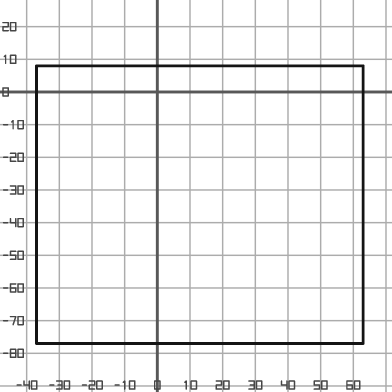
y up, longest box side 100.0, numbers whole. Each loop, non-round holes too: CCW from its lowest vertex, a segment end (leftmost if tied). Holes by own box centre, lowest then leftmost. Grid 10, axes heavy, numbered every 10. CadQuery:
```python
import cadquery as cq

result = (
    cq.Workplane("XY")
    .moveTo(-37.0, -77.0)
    .lineTo(63.0, -77.0)
    .lineTo(63.0, 8.0)
    .lineTo(-37.0, 8.0)
    .close()
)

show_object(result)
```